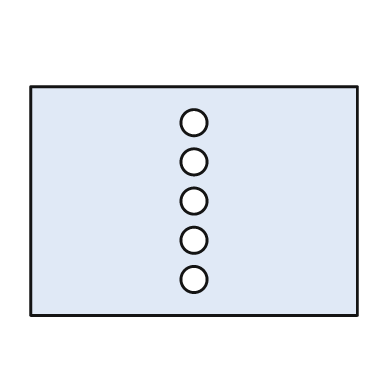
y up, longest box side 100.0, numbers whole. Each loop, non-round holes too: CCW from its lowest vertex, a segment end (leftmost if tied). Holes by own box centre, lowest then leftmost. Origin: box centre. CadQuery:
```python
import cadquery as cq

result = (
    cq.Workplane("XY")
    .moveTo(-50.0, -35.0)
    .lineTo(50.0, -35.0)
    .lineTo(50.0, 35.0)
    .lineTo(-50.0, 35.0)
    .close()
    .moveTo(0.0, -24.0)
    .circle(4.0)
    .moveTo(0.0, -12.0)
    .circle(4.0)
    .moveTo(0.0, 0.0)
    .circle(4.0)
    .moveTo(0.0, 12.0)
    .circle(4.0)
    .moveTo(0.0, 24.0)
    .circle(4.0)
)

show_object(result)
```